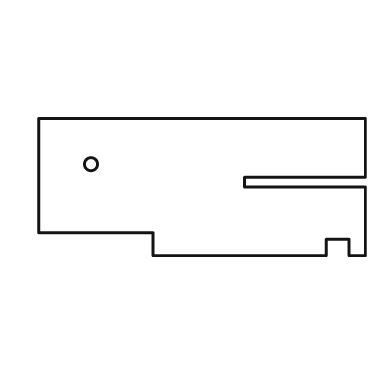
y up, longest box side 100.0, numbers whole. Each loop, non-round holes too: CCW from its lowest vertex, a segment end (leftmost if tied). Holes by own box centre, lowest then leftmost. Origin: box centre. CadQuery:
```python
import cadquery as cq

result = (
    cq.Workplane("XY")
    .moveTo(-15.0, -21.0)
    .lineTo(38.0, -21.0)
    .lineTo(38.0, -16.0)
    .lineTo(45.0, -16.0)
    .lineTo(45.0, -21.0)
    .lineTo(50.0, -21.0)
    .lineTo(50.0, 0.0)
    .lineTo(13.0, 0.0)
    .lineTo(13.0, 3.0)
    .lineTo(50.0, 3.0)
    .lineTo(50.0, 21.0)
    .lineTo(-50.0, 21.0)
    .lineTo(-50.0, -14.0)
    .lineTo(-15.0, -14.0)
    .close()
    .moveTo(-34.0, 7.0)
    .circle(2.0)
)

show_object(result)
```